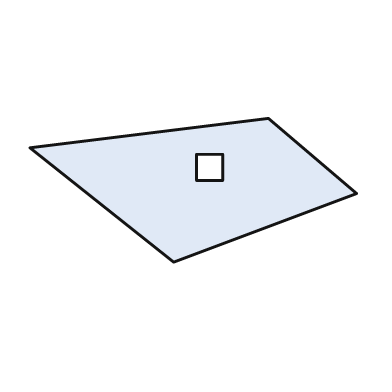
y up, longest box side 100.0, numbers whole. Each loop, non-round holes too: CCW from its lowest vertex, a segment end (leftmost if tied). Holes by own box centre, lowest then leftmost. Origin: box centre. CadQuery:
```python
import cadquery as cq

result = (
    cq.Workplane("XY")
    .moveTo(-6.0, -22.0)
    .lineTo(50.0, -1.0)
    .lineTo(23.0, 22.0)
    .lineTo(-50.0, 13.0)
    .close()
    .moveTo(1.0, 3.0)
    .lineTo(9.0, 3.0)
    .lineTo(9.0, 11.0)
    .lineTo(1.0, 11.0)
    .close()
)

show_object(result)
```